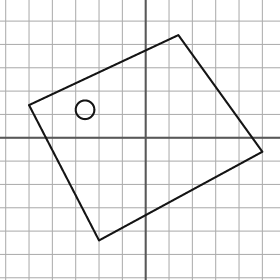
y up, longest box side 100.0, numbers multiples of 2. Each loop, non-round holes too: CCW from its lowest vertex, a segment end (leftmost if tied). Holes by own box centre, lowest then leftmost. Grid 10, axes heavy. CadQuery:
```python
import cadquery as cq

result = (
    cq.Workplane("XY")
    .moveTo(-20.0, -44.0)
    .lineTo(50.0, -6.0)
    .lineTo(14.0, 44.0)
    .lineTo(-50.0, 14.0)
    .close()
    .moveTo(-26.0, 12.0)
    .circle(4.0)
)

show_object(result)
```